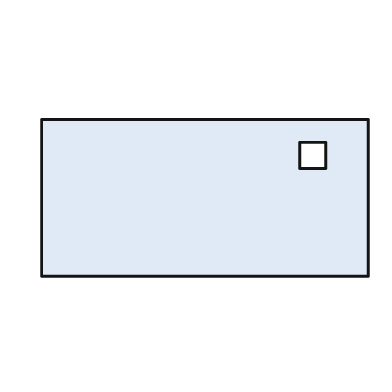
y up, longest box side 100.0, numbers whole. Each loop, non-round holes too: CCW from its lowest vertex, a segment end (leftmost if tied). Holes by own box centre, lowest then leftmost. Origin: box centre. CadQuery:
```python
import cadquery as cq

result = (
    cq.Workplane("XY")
    .moveTo(-50.0, -24.0)
    .lineTo(50.0, -24.0)
    .lineTo(50.0, 24.0)
    .lineTo(-50.0, 24.0)
    .close()
    .moveTo(29.0, 9.0)
    .lineTo(37.0, 9.0)
    .lineTo(37.0, 17.0)
    .lineTo(29.0, 17.0)
    .close()
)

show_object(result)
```